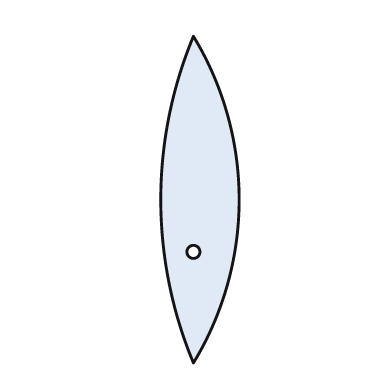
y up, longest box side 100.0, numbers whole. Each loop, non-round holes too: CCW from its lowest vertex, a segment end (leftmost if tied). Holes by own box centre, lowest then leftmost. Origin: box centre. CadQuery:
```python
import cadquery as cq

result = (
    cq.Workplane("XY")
    .moveTo(-2.0, -50.0)
    .threePointArc((12.0, 0.0), (-2.0, 50.0))
    .threePointArc((-12.0, 0.0), (-2.0, -50.0))
    .close()
    .moveTo(-2.0, -16.0)
    .circle(2.0)
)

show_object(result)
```